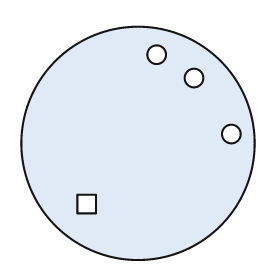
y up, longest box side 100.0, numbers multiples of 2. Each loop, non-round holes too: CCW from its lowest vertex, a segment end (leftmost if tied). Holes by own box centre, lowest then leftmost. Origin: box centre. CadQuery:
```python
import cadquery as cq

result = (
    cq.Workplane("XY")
    .moveTo(0.0, 0.0)
    .circle(50.0)
    .moveTo(-26.0, -30.0)
    .lineTo(-18.0, -30.0)
    .lineTo(-18.0, -22.0)
    .lineTo(-26.0, -22.0)
    .close()
    .moveTo(40.0, 4.0)
    .circle(4.0)
    .moveTo(24.0, 28.0)
    .circle(4.0)
    .moveTo(8.0, 38.0)
    .circle(4.0)
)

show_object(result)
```